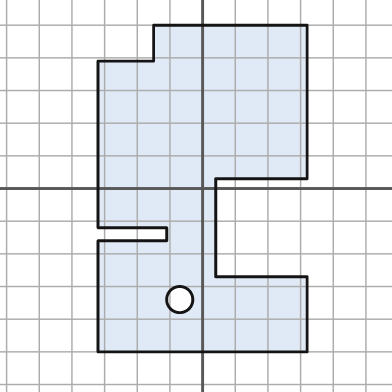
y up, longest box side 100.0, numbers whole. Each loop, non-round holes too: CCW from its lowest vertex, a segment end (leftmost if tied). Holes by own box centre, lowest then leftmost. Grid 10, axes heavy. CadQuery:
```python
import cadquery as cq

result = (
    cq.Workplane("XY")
    .moveTo(-32.0, -50.0)
    .lineTo(32.0, -50.0)
    .lineTo(32.0, -27.0)
    .lineTo(4.0, -27.0)
    .lineTo(4.0, 3.0)
    .lineTo(32.0, 3.0)
    .lineTo(32.0, 50.0)
    .lineTo(-15.0, 50.0)
    .lineTo(-15.0, 39.0)
    .lineTo(-32.0, 39.0)
    .lineTo(-32.0, -12.0)
    .lineTo(-11.0, -12.0)
    .lineTo(-11.0, -16.0)
    .lineTo(-32.0, -16.0)
    .close()
    .moveTo(-7.0, -34.0)
    .circle(4.0)
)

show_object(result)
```